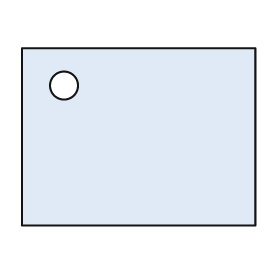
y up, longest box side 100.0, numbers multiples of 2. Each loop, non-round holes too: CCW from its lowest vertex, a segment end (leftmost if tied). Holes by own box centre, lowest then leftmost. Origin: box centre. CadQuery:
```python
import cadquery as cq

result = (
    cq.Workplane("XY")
    .moveTo(-50.0, -38.0)
    .lineTo(50.0, -38.0)
    .lineTo(50.0, 38.0)
    .lineTo(-50.0, 38.0)
    .close()
    .moveTo(-32.0, 22.0)
    .circle(6.0)
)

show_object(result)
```